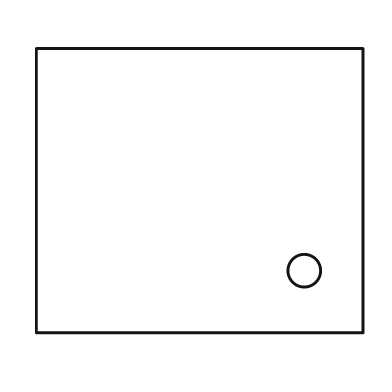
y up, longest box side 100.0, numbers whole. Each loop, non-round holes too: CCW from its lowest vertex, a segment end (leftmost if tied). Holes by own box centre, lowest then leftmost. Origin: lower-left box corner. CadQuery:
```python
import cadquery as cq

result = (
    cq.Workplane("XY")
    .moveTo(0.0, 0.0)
    .lineTo(100.0, 0.0)
    .lineTo(100.0, 87.0)
    .lineTo(0.0, 87.0)
    .close()
    .moveTo(82.0, 19.0)
    .circle(5.0)
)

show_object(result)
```